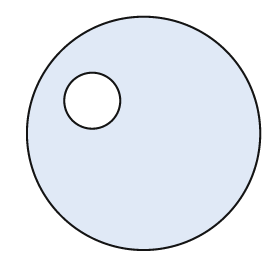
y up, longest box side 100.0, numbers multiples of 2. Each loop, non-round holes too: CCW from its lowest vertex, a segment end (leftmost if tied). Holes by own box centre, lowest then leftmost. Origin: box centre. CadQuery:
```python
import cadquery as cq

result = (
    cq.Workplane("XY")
    .moveTo(0.0, 0.0)
    .circle(50.0)
    .moveTo(-22.0, 14.0)
    .circle(12.0)
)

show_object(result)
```